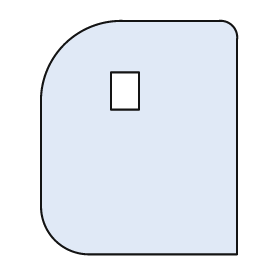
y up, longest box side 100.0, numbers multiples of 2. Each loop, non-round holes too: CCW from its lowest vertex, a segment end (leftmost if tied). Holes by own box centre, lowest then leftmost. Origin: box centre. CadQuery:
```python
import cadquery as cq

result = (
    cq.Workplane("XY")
    .moveTo(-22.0, -50.0)
    .lineTo(42.0, -50.0)
    .lineTo(42.0, 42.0)
    .threePointArc((40.0, 48.0), (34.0, 50.0))
    .lineTo(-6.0, 50.0)
    .threePointArc((-32.0, 40.0), (-42.0, 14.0))
    .lineTo(-42.0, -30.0)
    .threePointArc((-36.0, -44.0), (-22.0, -50.0))
    .close()
    .moveTo(-12.0, 12.0)
    .lineTo(0.0, 12.0)
    .lineTo(0.0, 28.0)
    .lineTo(-12.0, 28.0)
    .close()
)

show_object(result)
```